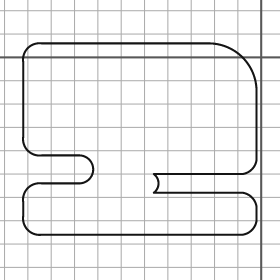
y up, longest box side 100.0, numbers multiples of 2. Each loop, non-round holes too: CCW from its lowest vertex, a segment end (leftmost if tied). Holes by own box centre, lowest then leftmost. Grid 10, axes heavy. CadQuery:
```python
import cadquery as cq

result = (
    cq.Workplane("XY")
    .moveTo(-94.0, -76.0)
    .lineTo(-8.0, -76.0)
    .threePointArc((-4.0, -74.0), (-2.0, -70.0))
    .lineTo(-2.0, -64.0)
    .threePointArc((-4.0, -60.0), (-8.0, -58.0))
    .lineTo(-46.0, -58.0)
    .threePointArc((-44.0, -54.0), (-46.0, -50.0))
    .lineTo(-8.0, -50.0)
    .threePointArc((-4.0, -48.0), (-2.0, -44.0))
    .lineTo(-2.0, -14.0)
    .threePointArc((-8.0, 0.0), (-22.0, 6.0))
    .lineTo(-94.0, 6.0)
    .threePointArc((-100.0, 4.0), (-102.0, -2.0))
    .lineTo(-102.0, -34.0)
    .threePointArc((-100.0, -40.0), (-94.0, -42.0))
    .lineTo(-78.0, -42.0)
    .threePointArc((-72.0, -48.0), (-78.0, -54.0))
    .lineTo(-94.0, -54.0)
    .threePointArc((-100.0, -56.0), (-102.0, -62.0))
    .lineTo(-102.0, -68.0)
    .threePointArc((-100.0, -74.0), (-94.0, -76.0))
    .close()
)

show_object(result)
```